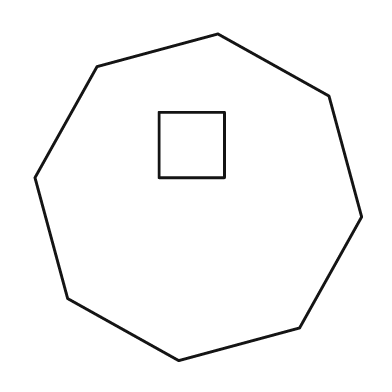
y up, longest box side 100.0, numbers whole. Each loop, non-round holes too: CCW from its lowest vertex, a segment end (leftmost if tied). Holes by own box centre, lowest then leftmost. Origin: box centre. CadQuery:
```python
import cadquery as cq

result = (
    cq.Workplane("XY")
    .moveTo(-6.0, -50.0)
    .lineTo(31.0, -40.0)
    .lineTo(50.0, -6.0)
    .lineTo(40.0, 31.0)
    .lineTo(6.0, 50.0)
    .lineTo(-31.0, 40.0)
    .lineTo(-50.0, 6.0)
    .lineTo(-40.0, -31.0)
    .close()
    .moveTo(-12.0, 6.0)
    .lineTo(8.0, 6.0)
    .lineTo(8.0, 26.0)
    .lineTo(-12.0, 26.0)
    .close()
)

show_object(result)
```